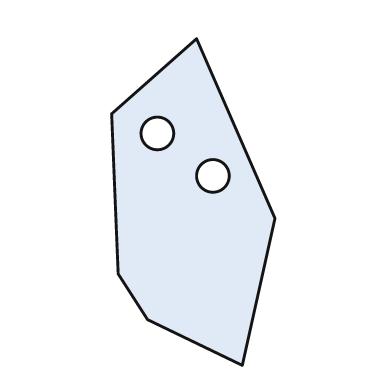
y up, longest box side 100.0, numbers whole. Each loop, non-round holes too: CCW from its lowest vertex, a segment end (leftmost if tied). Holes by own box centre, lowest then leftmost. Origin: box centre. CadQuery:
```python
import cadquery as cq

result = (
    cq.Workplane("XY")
    .moveTo(15.0, -50.0)
    .lineTo(25.0, -5.0)
    .lineTo(1.0, 50.0)
    .lineTo(-25.0, 27.0)
    .lineTo(-23.0, -22.0)
    .lineTo(-14.0, -36.0)
    .close()
    .moveTo(6.0, 8.0)
    .circle(5.0)
    .moveTo(-11.0, 21.0)
    .circle(5.0)
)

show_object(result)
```